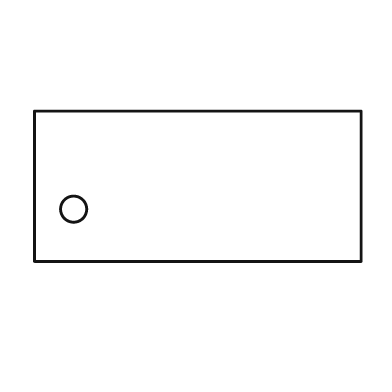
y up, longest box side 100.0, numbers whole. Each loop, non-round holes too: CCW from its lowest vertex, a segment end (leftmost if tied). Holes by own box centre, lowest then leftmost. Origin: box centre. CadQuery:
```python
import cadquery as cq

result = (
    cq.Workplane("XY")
    .moveTo(-50.0, -23.0)
    .lineTo(50.0, -23.0)
    .lineTo(50.0, 23.0)
    .lineTo(-50.0, 23.0)
    .close()
    .moveTo(-38.0, -7.0)
    .circle(4.0)
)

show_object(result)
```